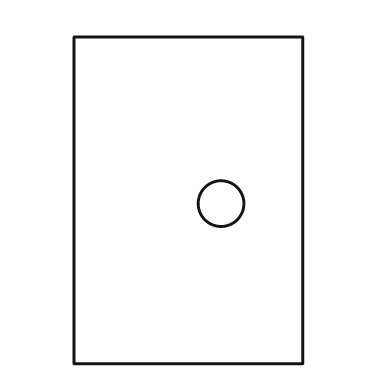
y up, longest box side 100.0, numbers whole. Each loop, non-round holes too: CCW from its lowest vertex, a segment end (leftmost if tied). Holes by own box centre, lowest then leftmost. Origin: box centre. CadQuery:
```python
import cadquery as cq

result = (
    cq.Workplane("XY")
    .moveTo(-35.0, -50.0)
    .lineTo(35.0, -50.0)
    .lineTo(35.0, 50.0)
    .lineTo(-35.0, 50.0)
    .close()
    .moveTo(10.0, -1.0)
    .circle(7.0)
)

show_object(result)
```